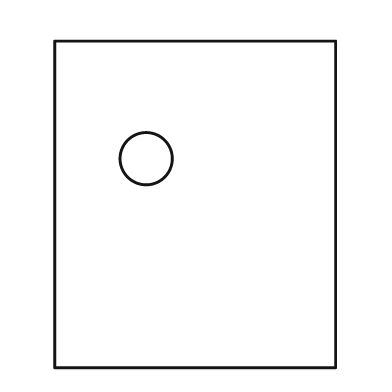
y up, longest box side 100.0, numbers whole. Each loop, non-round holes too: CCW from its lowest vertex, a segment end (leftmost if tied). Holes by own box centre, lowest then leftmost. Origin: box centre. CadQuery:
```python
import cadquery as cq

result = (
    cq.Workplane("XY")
    .moveTo(-43.0, -50.0)
    .lineTo(43.0, -50.0)
    .lineTo(43.0, 50.0)
    .lineTo(-43.0, 50.0)
    .close()
    .moveTo(-15.0, 14.0)
    .circle(8.0)
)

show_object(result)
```